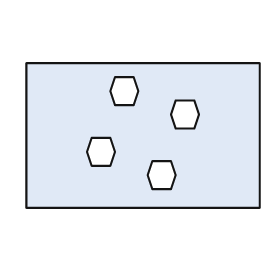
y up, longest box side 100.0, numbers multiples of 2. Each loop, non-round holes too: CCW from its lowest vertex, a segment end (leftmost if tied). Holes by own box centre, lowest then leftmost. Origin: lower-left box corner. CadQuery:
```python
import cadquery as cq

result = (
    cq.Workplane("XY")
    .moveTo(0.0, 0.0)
    .lineTo(100.0, 0.0)
    .lineTo(100.0, 62.0)
    .lineTo(0.0, 62.0)
    .close()
    .moveTo(54.0, 8.0)
    .lineTo(62.0, 8.0)
    .lineTo(64.0, 14.0)
    .lineTo(62.0, 20.0)
    .lineTo(54.0, 20.0)
    .lineTo(52.0, 14.0)
    .close()
    .moveTo(28.0, 18.0)
    .lineTo(36.0, 18.0)
    .lineTo(38.0, 24.0)
    .lineTo(36.0, 30.0)
    .lineTo(28.0, 30.0)
    .lineTo(26.0, 24.0)
    .close()
    .moveTo(64.0, 34.0)
    .lineTo(72.0, 34.0)
    .lineTo(74.0, 40.0)
    .lineTo(72.0, 46.0)
    .lineTo(64.0, 46.0)
    .lineTo(62.0, 40.0)
    .close()
    .moveTo(38.0, 44.0)
    .lineTo(46.0, 44.0)
    .lineTo(48.0, 50.0)
    .lineTo(46.0, 56.0)
    .lineTo(38.0, 56.0)
    .lineTo(36.0, 50.0)
    .close()
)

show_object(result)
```